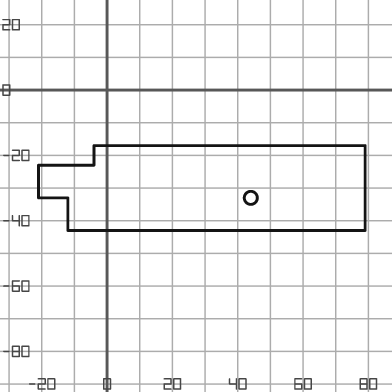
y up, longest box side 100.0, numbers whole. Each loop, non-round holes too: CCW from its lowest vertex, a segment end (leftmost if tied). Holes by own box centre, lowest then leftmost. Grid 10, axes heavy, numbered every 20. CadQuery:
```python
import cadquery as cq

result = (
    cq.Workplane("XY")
    .moveTo(-12.0, -43.0)
    .lineTo(79.0, -43.0)
    .lineTo(79.0, -17.0)
    .lineTo(-4.0, -17.0)
    .lineTo(-4.0, -23.0)
    .lineTo(-21.0, -23.0)
    .lineTo(-21.0, -33.0)
    .lineTo(-12.0, -33.0)
    .close()
    .moveTo(44.0, -33.0)
    .circle(2.0)
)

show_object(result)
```